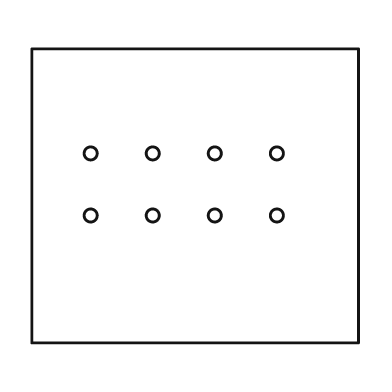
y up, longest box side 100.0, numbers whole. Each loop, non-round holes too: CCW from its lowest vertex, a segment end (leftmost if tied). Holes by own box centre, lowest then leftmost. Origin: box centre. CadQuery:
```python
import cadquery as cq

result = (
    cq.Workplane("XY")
    .moveTo(-50.0, -45.0)
    .lineTo(50.0, -45.0)
    .lineTo(50.0, 45.0)
    .lineTo(-50.0, 45.0)
    .close()
    .moveTo(-32.0, -6.0)
    .circle(2.0)
    .moveTo(-13.0, -6.0)
    .circle(2.0)
    .moveTo(6.0, -6.0)
    .circle(2.0)
    .moveTo(25.0, -6.0)
    .circle(2.0)
    .moveTo(-32.0, 13.0)
    .circle(2.0)
    .moveTo(-13.0, 13.0)
    .circle(2.0)
    .moveTo(6.0, 13.0)
    .circle(2.0)
    .moveTo(25.0, 13.0)
    .circle(2.0)
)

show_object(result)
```